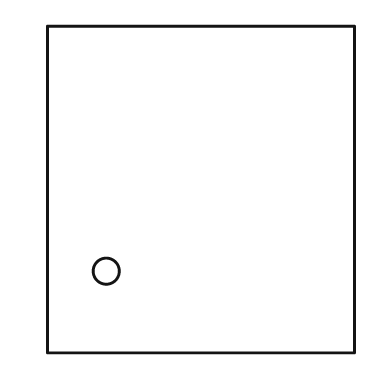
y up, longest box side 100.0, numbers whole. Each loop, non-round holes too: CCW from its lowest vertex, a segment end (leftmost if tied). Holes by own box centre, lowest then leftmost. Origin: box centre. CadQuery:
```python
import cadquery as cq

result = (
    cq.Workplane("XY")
    .moveTo(-47.0, -50.0)
    .lineTo(47.0, -50.0)
    .lineTo(47.0, 50.0)
    .lineTo(-47.0, 50.0)
    .close()
    .moveTo(-29.0, -25.0)
    .circle(4.0)
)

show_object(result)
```